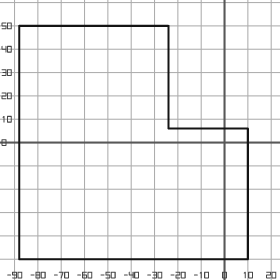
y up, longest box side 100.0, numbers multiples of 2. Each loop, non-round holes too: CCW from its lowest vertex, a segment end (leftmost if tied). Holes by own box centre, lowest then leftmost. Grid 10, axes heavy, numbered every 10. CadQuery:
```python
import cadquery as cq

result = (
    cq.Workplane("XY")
    .moveTo(-88.0, -50.0)
    .lineTo(10.0, -50.0)
    .lineTo(10.0, 6.0)
    .lineTo(-24.0, 6.0)
    .lineTo(-24.0, 50.0)
    .lineTo(-88.0, 50.0)
    .close()
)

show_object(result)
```